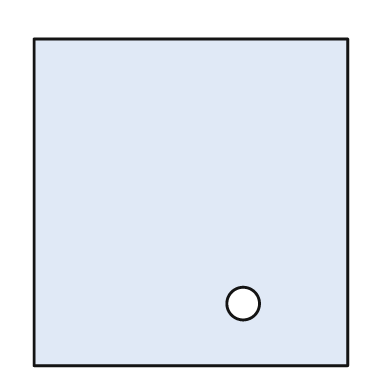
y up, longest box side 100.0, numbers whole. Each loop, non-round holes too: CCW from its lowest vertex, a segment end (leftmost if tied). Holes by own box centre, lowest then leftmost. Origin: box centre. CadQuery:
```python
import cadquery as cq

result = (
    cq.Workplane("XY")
    .moveTo(-48.0, -50.0)
    .lineTo(48.0, -50.0)
    .lineTo(48.0, 50.0)
    .lineTo(-48.0, 50.0)
    .close()
    .moveTo(16.0, -31.0)
    .circle(5.0)
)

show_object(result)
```